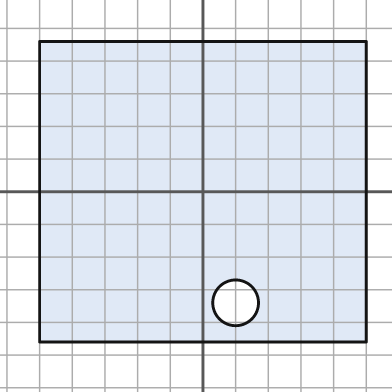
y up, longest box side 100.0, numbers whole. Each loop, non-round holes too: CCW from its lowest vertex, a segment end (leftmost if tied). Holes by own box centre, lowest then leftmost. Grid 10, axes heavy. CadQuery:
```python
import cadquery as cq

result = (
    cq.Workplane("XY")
    .moveTo(-50.0, -46.0)
    .lineTo(50.0, -46.0)
    .lineTo(50.0, 46.0)
    .lineTo(-50.0, 46.0)
    .close()
    .moveTo(10.0, -34.0)
    .circle(7.0)
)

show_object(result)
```